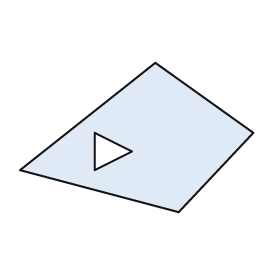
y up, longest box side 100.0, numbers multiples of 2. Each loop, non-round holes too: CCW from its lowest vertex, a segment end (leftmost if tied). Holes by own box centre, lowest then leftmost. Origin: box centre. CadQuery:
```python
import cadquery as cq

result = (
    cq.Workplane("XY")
    .moveTo(18.0, -32.0)
    .lineTo(50.0, 2.0)
    .lineTo(8.0, 32.0)
    .lineTo(-50.0, -14.0)
    .close()
    .moveTo(-18.0, -14.0)
    .lineTo(-2.0, -6.0)
    .lineTo(-18.0, 2.0)
    .close()
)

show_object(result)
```